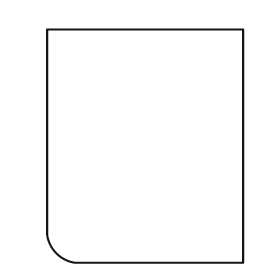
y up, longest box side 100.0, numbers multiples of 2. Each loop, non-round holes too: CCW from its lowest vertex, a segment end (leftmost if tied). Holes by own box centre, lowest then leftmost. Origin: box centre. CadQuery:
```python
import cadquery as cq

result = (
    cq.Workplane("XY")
    .moveTo(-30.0, -50.0)
    .lineTo(42.0, -50.0)
    .lineTo(42.0, 50.0)
    .lineTo(-42.0, 50.0)
    .lineTo(-42.0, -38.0)
    .threePointArc((-38.0, -46.0), (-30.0, -50.0))
    .close()
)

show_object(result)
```